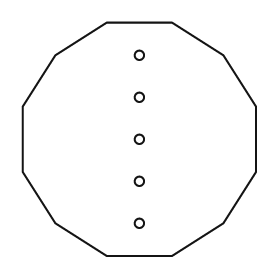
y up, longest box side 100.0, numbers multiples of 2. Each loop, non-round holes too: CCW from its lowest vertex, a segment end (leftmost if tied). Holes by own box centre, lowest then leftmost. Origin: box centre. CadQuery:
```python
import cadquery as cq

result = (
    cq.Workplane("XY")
    .moveTo(-14.0, -50.0)
    .lineTo(14.0, -50.0)
    .lineTo(36.0, -36.0)
    .lineTo(50.0, -14.0)
    .lineTo(50.0, 14.0)
    .lineTo(36.0, 36.0)
    .lineTo(14.0, 50.0)
    .lineTo(-14.0, 50.0)
    .lineTo(-36.0, 36.0)
    .lineTo(-50.0, 14.0)
    .lineTo(-50.0, -14.0)
    .lineTo(-36.0, -36.0)
    .close()
    .moveTo(0.0, -36.0)
    .circle(2.0)
    .moveTo(0.0, -18.0)
    .circle(2.0)
    .moveTo(0.0, 0.0)
    .circle(2.0)
    .moveTo(0.0, 18.0)
    .circle(2.0)
    .moveTo(0.0, 36.0)
    .circle(2.0)
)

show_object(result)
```